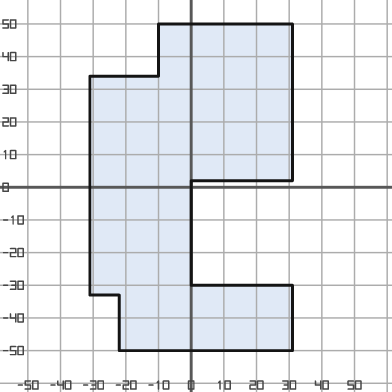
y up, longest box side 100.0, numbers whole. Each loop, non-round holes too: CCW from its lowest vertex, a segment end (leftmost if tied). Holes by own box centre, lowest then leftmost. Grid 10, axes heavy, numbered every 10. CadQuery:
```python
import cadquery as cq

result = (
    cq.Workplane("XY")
    .moveTo(-22.0, -50.0)
    .lineTo(31.0, -50.0)
    .lineTo(31.0, -30.0)
    .lineTo(0.0, -30.0)
    .lineTo(0.0, 2.0)
    .lineTo(31.0, 2.0)
    .lineTo(31.0, 50.0)
    .lineTo(-10.0, 50.0)
    .lineTo(-10.0, 34.0)
    .lineTo(-31.0, 34.0)
    .lineTo(-31.0, -33.0)
    .lineTo(-22.0, -33.0)
    .close()
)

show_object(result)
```